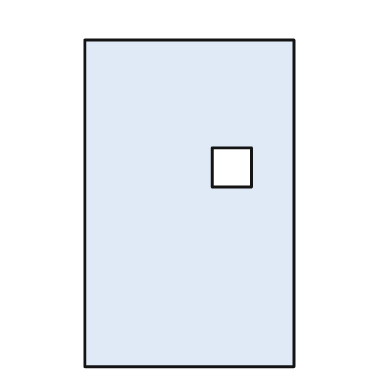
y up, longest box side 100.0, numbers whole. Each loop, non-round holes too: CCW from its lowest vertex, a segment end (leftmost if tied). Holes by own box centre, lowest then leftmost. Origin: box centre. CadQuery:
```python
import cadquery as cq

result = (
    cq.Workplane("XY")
    .moveTo(-32.0, -50.0)
    .lineTo(32.0, -50.0)
    .lineTo(32.0, 50.0)
    .lineTo(-32.0, 50.0)
    .close()
    .moveTo(7.0, 5.0)
    .lineTo(19.0, 5.0)
    .lineTo(19.0, 17.0)
    .lineTo(7.0, 17.0)
    .close()
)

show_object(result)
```